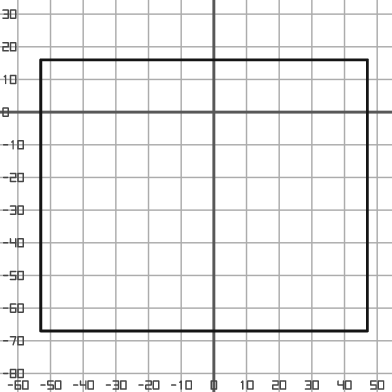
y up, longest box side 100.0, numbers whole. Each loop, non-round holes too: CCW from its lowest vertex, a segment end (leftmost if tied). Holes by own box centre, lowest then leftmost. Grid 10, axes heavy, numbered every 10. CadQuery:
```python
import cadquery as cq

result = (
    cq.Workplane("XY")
    .moveTo(-53.0, -67.0)
    .lineTo(47.0, -67.0)
    .lineTo(47.0, 16.0)
    .lineTo(-53.0, 16.0)
    .close()
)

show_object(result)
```